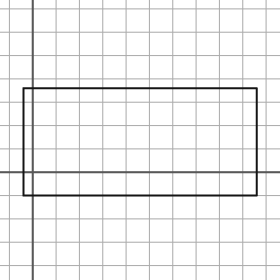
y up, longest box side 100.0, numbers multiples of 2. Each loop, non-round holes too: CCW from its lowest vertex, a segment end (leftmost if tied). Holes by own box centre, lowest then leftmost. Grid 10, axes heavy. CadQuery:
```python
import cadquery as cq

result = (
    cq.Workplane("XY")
    .moveTo(-4.0, -10.0)
    .lineTo(96.0, -10.0)
    .lineTo(96.0, 36.0)
    .lineTo(-4.0, 36.0)
    .close()
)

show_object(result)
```